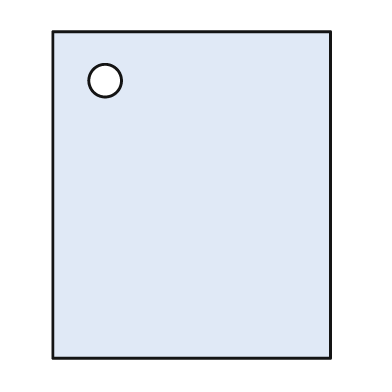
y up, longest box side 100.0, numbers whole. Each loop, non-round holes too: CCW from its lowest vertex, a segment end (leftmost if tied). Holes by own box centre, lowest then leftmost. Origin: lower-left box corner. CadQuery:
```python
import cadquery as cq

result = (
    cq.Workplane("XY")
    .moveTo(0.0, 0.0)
    .lineTo(85.0, 0.0)
    .lineTo(85.0, 100.0)
    .lineTo(0.0, 100.0)
    .close()
    .moveTo(16.0, 85.0)
    .circle(5.0)
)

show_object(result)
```